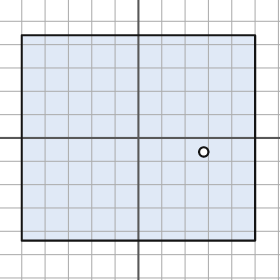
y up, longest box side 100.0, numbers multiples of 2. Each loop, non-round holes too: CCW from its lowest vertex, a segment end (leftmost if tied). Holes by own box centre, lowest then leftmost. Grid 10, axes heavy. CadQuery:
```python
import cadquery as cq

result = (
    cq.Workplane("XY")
    .moveTo(-50.0, -44.0)
    .lineTo(50.0, -44.0)
    .lineTo(50.0, 44.0)
    .lineTo(-50.0, 44.0)
    .close()
    .moveTo(28.0, -6.0)
    .circle(2.0)
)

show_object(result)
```